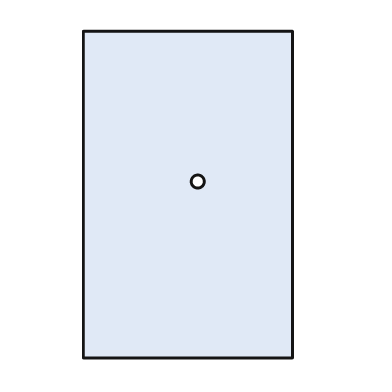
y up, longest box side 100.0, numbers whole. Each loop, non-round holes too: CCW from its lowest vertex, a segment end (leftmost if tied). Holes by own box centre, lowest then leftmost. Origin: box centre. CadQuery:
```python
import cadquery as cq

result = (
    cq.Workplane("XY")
    .moveTo(-32.0, -50.0)
    .lineTo(32.0, -50.0)
    .lineTo(32.0, 50.0)
    .lineTo(-32.0, 50.0)
    .close()
    .moveTo(3.0, 4.0)
    .circle(2.0)
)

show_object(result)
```